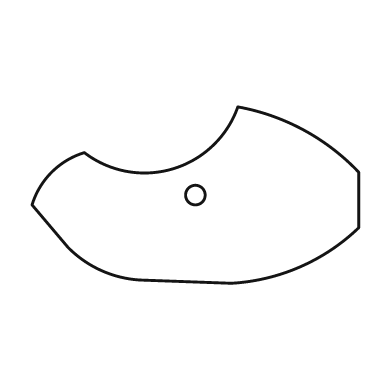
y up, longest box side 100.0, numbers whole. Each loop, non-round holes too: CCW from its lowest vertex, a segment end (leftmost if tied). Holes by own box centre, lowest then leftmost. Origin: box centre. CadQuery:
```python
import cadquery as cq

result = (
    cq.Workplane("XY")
    .moveTo(11.0, -27.0)
    .threePointArc((32.0, -22.0), (50.0, -10.0))
    .lineTo(50.0, 7.0)
    .threePointArc((33.0, 20.0), (13.0, 27.0))
    .threePointArc((-7.0, 8.0), (-34.0, 13.0))
    .threePointArc((-44.0, 7.0), (-50.0, -3.0))
    .lineTo(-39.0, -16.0)
    .threePointArc((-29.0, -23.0), (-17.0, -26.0))
    .close()
    .moveTo(0.0, 0.0)
    .circle(3.0)
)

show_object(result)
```